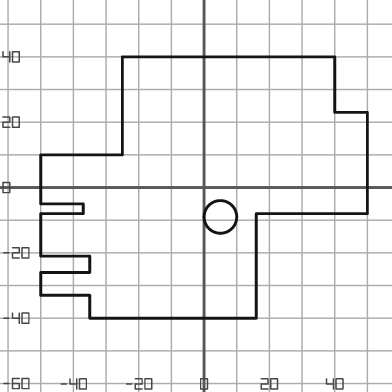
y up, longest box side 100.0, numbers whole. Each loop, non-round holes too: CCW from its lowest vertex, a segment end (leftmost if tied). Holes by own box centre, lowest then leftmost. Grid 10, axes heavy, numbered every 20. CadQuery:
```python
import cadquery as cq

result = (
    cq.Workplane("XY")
    .moveTo(-35.0, -40.0)
    .lineTo(16.0, -40.0)
    .lineTo(16.0, -8.0)
    .lineTo(50.0, -8.0)
    .lineTo(50.0, 23.0)
    .lineTo(40.0, 23.0)
    .lineTo(40.0, 40.0)
    .lineTo(-25.0, 40.0)
    .lineTo(-25.0, 10.0)
    .lineTo(-50.0, 10.0)
    .lineTo(-50.0, -5.0)
    .lineTo(-37.0, -5.0)
    .lineTo(-37.0, -8.0)
    .lineTo(-50.0, -8.0)
    .lineTo(-50.0, -21.0)
    .lineTo(-35.0, -21.0)
    .lineTo(-35.0, -26.0)
    .lineTo(-50.0, -26.0)
    .lineTo(-50.0, -33.0)
    .lineTo(-35.0, -33.0)
    .close()
    .moveTo(5.0, -9.0)
    .circle(5.0)
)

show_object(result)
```